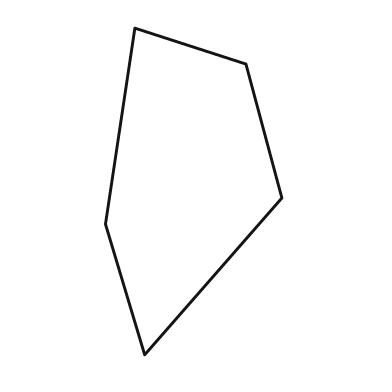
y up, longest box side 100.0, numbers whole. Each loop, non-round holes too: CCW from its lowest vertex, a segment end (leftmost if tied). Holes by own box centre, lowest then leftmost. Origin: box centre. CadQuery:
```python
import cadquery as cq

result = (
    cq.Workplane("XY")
    .moveTo(-15.0, -50.0)
    .lineTo(27.0, -2.0)
    .lineTo(16.0, 39.0)
    .lineTo(-18.0, 50.0)
    .lineTo(-27.0, -10.0)
    .close()
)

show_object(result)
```